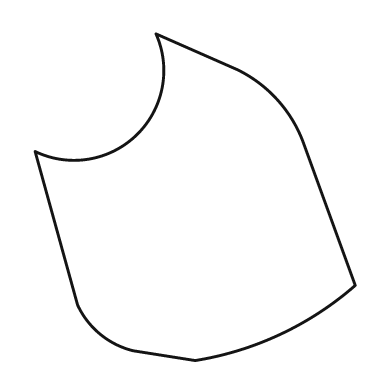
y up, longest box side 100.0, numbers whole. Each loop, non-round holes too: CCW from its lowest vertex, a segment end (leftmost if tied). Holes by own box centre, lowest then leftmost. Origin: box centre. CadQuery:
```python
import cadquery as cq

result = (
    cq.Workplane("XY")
    .moveTo(0.0, -50.0)
    .threePointArc((26.0, -42.0), (49.0, -27.0))
    .lineTo(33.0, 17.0)
    .threePointArc((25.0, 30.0), (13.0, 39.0))
    .lineTo(-12.0, 50.0)
    .threePointArc((-18.0, 19.0), (-49.0, 14.0))
    .lineTo(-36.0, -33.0)
    .threePointArc((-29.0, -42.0), (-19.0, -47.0))
    .close()
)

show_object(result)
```